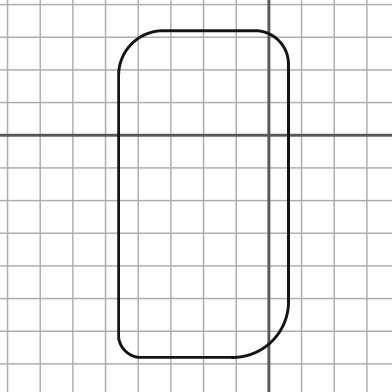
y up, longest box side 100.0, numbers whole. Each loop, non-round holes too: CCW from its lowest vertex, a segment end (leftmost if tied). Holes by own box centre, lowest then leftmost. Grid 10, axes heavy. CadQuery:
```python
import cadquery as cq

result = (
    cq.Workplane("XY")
    .moveTo(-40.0, -68.0)
    .lineTo(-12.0, -68.0)
    .threePointArc((1.0, -63.0), (6.0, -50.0))
    .lineTo(6.0, 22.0)
    .threePointArc((3.0, 29.0), (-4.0, 32.0))
    .lineTo(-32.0, 32.0)
    .threePointArc((-42.0, 28.0), (-46.0, 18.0))
    .lineTo(-46.0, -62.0)
    .threePointArc((-44.0, -66.0), (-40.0, -68.0))
    .close()
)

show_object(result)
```